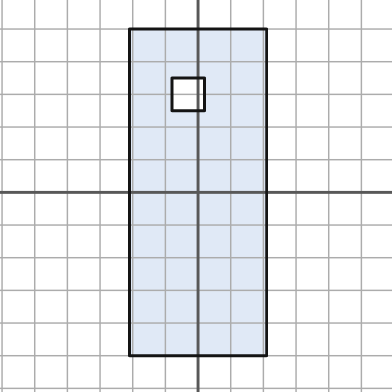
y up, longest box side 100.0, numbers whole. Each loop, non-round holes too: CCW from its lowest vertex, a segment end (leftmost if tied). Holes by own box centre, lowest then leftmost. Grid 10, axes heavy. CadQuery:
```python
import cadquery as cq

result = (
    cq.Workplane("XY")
    .moveTo(-21.0, -50.0)
    .lineTo(21.0, -50.0)
    .lineTo(21.0, 50.0)
    .lineTo(-21.0, 50.0)
    .close()
    .moveTo(-8.0, 25.0)
    .lineTo(2.0, 25.0)
    .lineTo(2.0, 35.0)
    .lineTo(-8.0, 35.0)
    .close()
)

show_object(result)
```